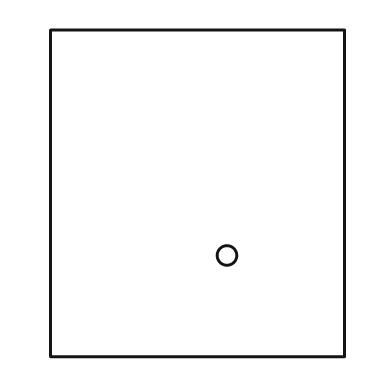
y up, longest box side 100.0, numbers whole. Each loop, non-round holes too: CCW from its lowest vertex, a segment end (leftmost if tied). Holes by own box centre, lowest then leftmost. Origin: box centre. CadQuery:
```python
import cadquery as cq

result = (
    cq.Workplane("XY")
    .moveTo(-45.0, -50.0)
    .lineTo(45.0, -50.0)
    .lineTo(45.0, 50.0)
    .lineTo(-45.0, 50.0)
    .close()
    .moveTo(9.0, -19.0)
    .circle(3.0)
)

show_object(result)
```